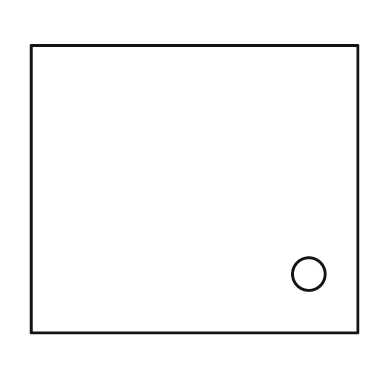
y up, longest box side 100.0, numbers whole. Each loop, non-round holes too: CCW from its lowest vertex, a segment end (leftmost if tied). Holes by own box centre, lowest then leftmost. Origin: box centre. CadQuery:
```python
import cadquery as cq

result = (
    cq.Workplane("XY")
    .moveTo(-50.0, -44.0)
    .lineTo(50.0, -44.0)
    .lineTo(50.0, 44.0)
    .lineTo(-50.0, 44.0)
    .close()
    .moveTo(35.0, -26.0)
    .circle(5.0)
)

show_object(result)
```